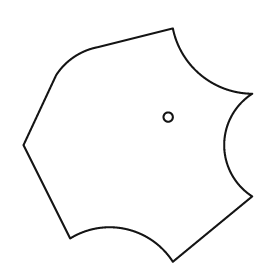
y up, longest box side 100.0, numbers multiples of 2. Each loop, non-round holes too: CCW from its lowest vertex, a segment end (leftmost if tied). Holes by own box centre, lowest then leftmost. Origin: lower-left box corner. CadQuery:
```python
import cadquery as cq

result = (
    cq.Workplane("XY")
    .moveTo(64.0, 0.0)
    .lineTo(98.0, 28.0)
    .threePointArc((86.0, 50.0), (98.0, 72.0))
    .threePointArc((76.0, 80.0), (64.0, 100.0))
    .lineTo(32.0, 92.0)
    .threePointArc((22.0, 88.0), (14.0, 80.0))
    .lineTo(0.0, 50.0)
    .lineTo(20.0, 10.0)
    .threePointArc((44.0, 14.0), (64.0, 0.0))
    .close()
    .moveTo(62.0, 62.0)
    .circle(2.0)
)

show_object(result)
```